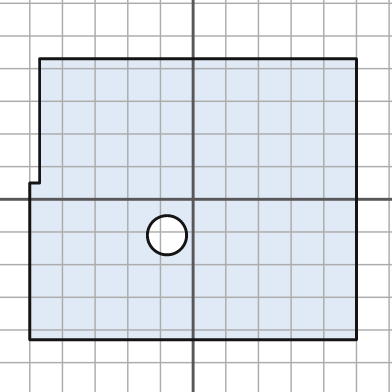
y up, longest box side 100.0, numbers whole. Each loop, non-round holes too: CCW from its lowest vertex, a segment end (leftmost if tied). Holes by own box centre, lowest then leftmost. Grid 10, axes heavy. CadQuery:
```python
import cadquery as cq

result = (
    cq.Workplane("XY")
    .moveTo(-50.0, -43.0)
    .lineTo(50.0, -43.0)
    .lineTo(50.0, 43.0)
    .lineTo(-47.0, 43.0)
    .lineTo(-47.0, 5.0)
    .lineTo(-50.0, 5.0)
    .close()
    .moveTo(-8.0, -11.0)
    .circle(6.0)
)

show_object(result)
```